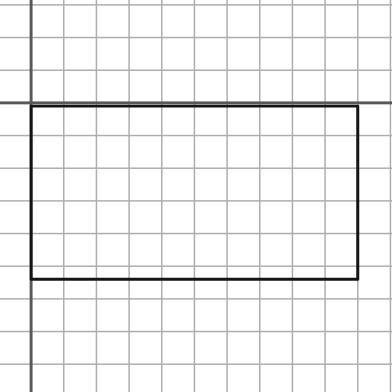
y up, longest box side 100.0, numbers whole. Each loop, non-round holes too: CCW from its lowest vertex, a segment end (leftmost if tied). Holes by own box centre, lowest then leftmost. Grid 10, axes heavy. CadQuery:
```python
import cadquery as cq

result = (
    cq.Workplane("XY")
    .moveTo(0.0, -54.0)
    .lineTo(100.0, -54.0)
    .lineTo(100.0, -1.0)
    .lineTo(0.0, -1.0)
    .close()
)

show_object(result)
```